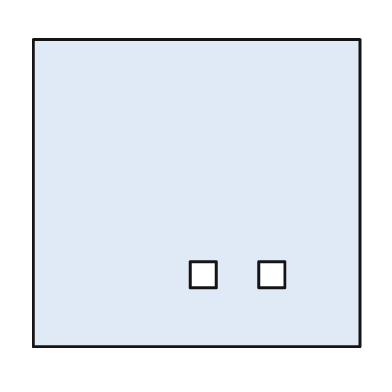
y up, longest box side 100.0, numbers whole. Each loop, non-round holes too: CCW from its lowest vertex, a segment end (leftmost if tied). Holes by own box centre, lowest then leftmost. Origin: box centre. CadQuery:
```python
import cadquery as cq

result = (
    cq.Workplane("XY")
    .moveTo(-50.0, -47.0)
    .lineTo(50.0, -47.0)
    .lineTo(50.0, 47.0)
    .lineTo(-50.0, 47.0)
    .close()
    .moveTo(-2.0, -29.0)
    .lineTo(6.0, -29.0)
    .lineTo(6.0, -21.0)
    .lineTo(-2.0, -21.0)
    .close()
    .moveTo(19.0, -29.0)
    .lineTo(27.0, -29.0)
    .lineTo(27.0, -21.0)
    .lineTo(19.0, -21.0)
    .close()
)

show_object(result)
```